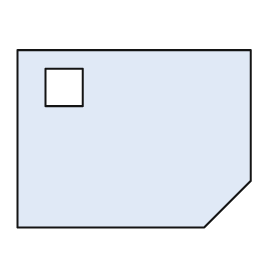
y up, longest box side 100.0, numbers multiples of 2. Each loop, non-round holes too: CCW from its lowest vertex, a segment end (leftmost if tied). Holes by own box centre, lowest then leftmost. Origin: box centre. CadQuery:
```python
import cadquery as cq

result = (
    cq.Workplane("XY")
    .moveTo(-50.0, -38.0)
    .lineTo(30.0, -38.0)
    .lineTo(50.0, -18.0)
    .lineTo(50.0, 38.0)
    .lineTo(-50.0, 38.0)
    .close()
    .moveTo(-38.0, 14.0)
    .lineTo(-22.0, 14.0)
    .lineTo(-22.0, 30.0)
    .lineTo(-38.0, 30.0)
    .close()
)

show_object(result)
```